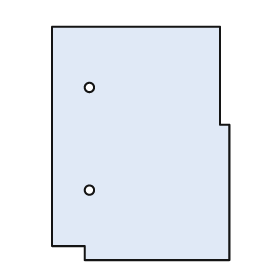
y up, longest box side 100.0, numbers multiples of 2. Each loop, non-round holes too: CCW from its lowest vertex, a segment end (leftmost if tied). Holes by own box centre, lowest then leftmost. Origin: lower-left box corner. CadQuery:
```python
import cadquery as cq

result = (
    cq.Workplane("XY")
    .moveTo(14.0, 0.0)
    .lineTo(76.0, 0.0)
    .lineTo(76.0, 58.0)
    .lineTo(72.0, 58.0)
    .lineTo(72.0, 100.0)
    .lineTo(0.0, 100.0)
    .lineTo(0.0, 6.0)
    .lineTo(14.0, 6.0)
    .close()
    .moveTo(16.0, 30.0)
    .circle(2.0)
    .moveTo(16.0, 74.0)
    .circle(2.0)
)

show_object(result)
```